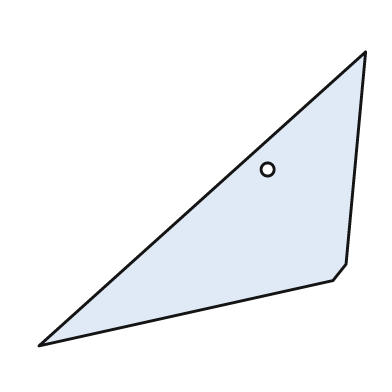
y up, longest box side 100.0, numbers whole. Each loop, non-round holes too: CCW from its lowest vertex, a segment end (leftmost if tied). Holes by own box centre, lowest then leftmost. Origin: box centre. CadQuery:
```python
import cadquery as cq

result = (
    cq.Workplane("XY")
    .moveTo(-50.0, -45.0)
    .lineTo(40.0, -25.0)
    .lineTo(44.0, -20.0)
    .lineTo(50.0, 45.0)
    .close()
    .moveTo(20.0, 9.0)
    .circle(2.0)
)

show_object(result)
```